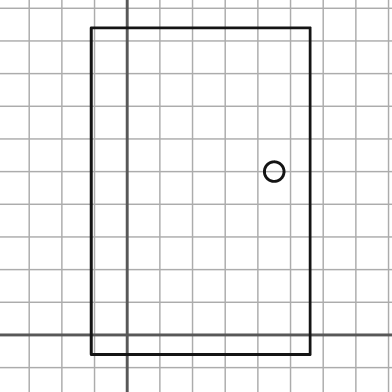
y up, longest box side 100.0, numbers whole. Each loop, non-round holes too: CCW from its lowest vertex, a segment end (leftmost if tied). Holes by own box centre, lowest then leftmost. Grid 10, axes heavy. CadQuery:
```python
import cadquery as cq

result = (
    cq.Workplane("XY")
    .moveTo(-11.0, -6.0)
    .lineTo(56.0, -6.0)
    .lineTo(56.0, 94.0)
    .lineTo(-11.0, 94.0)
    .close()
    .moveTo(45.0, 50.0)
    .circle(3.0)
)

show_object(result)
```